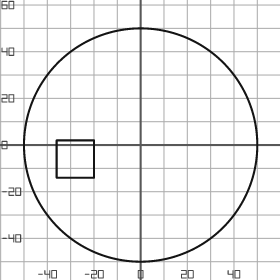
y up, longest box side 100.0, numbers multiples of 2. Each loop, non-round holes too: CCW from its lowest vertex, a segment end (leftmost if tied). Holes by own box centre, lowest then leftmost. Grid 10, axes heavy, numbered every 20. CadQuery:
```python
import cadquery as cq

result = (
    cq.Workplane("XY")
    .moveTo(0.0, 0.0)
    .circle(50.0)
    .moveTo(-36.0, -14.0)
    .lineTo(-20.0, -14.0)
    .lineTo(-20.0, 2.0)
    .lineTo(-36.0, 2.0)
    .close()
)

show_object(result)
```